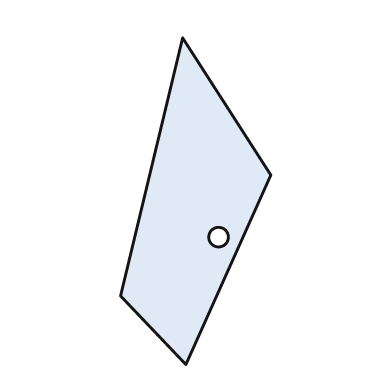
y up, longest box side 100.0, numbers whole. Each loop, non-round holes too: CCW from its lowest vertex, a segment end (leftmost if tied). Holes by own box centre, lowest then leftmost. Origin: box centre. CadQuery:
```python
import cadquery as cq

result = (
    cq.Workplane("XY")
    .moveTo(-3.0, -50.0)
    .lineTo(23.0, 8.0)
    .lineTo(-4.0, 50.0)
    .lineTo(-23.0, -29.0)
    .close()
    .moveTo(7.0, -11.0)
    .circle(3.0)
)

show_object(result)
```